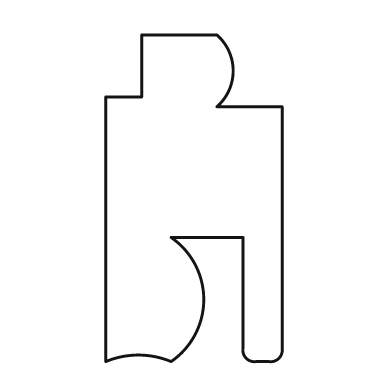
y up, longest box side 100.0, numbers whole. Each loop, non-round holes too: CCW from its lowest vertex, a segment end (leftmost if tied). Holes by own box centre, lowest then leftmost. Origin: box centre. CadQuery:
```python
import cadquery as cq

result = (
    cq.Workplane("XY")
    .moveTo(-27.0, -50.0)
    .threePointArc((-17.0, -48.0), (-7.0, -50.0))
    .threePointArc((3.0, -31.0), (-7.0, -12.0))
    .lineTo(15.0, -12.0)
    .lineTo(15.0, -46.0)
    .threePointArc((16.0, -49.0), (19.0, -50.0))
    .lineTo(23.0, -50.0)
    .threePointArc((26.0, -49.0), (27.0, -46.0))
    .lineTo(27.0, 28.0)
    .lineTo(7.0, 28.0)
    .threePointArc((12.0, 39.0), (7.0, 50.0))
    .lineTo(-16.0, 50.0)
    .lineTo(-16.0, 31.0)
    .lineTo(-27.0, 31.0)
    .close()
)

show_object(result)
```